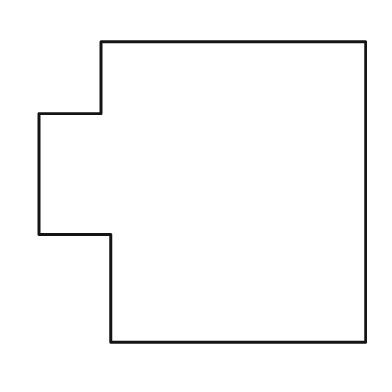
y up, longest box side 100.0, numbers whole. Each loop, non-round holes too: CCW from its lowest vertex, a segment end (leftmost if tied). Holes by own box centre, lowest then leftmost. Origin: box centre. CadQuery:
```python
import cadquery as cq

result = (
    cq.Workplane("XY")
    .moveTo(-28.0, -46.0)
    .lineTo(50.0, -46.0)
    .lineTo(50.0, 46.0)
    .lineTo(-31.0, 46.0)
    .lineTo(-31.0, 24.0)
    .lineTo(-50.0, 24.0)
    .lineTo(-50.0, -13.0)
    .lineTo(-28.0, -13.0)
    .close()
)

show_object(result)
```